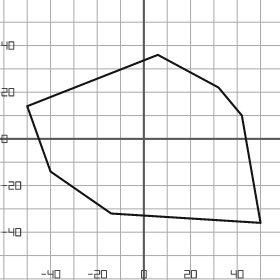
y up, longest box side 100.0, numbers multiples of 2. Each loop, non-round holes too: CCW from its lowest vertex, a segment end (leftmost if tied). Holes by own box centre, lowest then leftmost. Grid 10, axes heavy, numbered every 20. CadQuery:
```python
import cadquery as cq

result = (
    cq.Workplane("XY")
    .moveTo(50.0, -36.0)
    .lineTo(42.0, 10.0)
    .lineTo(32.0, 22.0)
    .lineTo(6.0, 36.0)
    .lineTo(-50.0, 14.0)
    .lineTo(-40.0, -14.0)
    .lineTo(-14.0, -32.0)
    .close()
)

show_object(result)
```